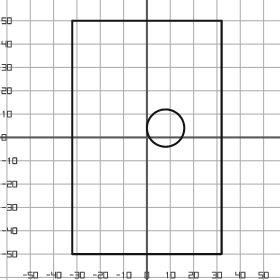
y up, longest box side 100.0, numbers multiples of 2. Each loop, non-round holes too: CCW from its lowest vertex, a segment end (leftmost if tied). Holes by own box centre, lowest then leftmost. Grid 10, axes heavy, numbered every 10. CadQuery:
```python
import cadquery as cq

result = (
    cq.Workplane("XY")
    .moveTo(-32.0, -50.0)
    .lineTo(32.0, -50.0)
    .lineTo(32.0, 50.0)
    .lineTo(-32.0, 50.0)
    .close()
    .moveTo(8.0, 4.0)
    .circle(8.0)
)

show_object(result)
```